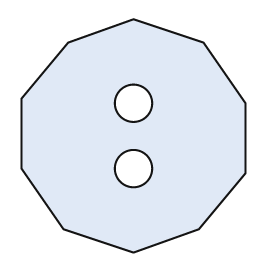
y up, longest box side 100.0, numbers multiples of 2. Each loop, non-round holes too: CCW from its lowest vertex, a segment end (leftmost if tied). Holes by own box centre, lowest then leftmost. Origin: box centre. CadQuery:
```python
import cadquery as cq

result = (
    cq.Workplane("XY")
    .moveTo(0.0, -50.0)
    .lineTo(28.0, -40.0)
    .lineTo(48.0, -16.0)
    .lineTo(48.0, 14.0)
    .lineTo(30.0, 40.0)
    .lineTo(0.0, 50.0)
    .lineTo(-28.0, 40.0)
    .lineTo(-48.0, 16.0)
    .lineTo(-48.0, -14.0)
    .lineTo(-30.0, -40.0)
    .close()
    .moveTo(0.0, -14.0)
    .circle(8.0)
    .moveTo(0.0, 14.0)
    .circle(8.0)
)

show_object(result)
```